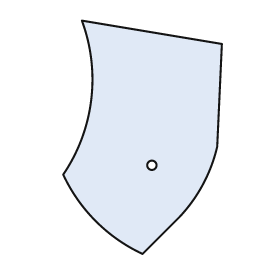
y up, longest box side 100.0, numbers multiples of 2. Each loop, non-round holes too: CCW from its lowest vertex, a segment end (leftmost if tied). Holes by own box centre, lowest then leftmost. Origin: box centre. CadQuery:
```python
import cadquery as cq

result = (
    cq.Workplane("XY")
    .moveTo(0.0, -50.0)
    .lineTo(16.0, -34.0)
    .threePointArc((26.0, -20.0), (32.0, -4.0))
    .lineTo(34.0, 40.0)
    .lineTo(-26.0, 50.0)
    .threePointArc((-22.0, 16.0), (-34.0, -16.0))
    .threePointArc((-20.0, -36.0), (0.0, -50.0))
    .close()
    .moveTo(4.0, -12.0)
    .circle(2.0)
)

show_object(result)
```